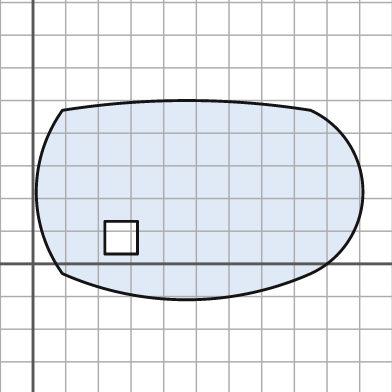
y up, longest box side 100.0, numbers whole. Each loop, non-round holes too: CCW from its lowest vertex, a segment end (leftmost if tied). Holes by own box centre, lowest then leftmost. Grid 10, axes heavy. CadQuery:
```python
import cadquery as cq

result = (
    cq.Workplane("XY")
    .moveTo(9.0, -3.0)
    .threePointArc((47.0, -11.0), (85.0, -3.0))
    .threePointArc((101.0, 22.0), (85.0, 47.0))
    .threePointArc((47.0, 50.0), (9.0, 47.0))
    .threePointArc((1.0, 22.0), (9.0, -3.0))
    .close()
    .moveTo(22.0, 3.0)
    .lineTo(32.0, 3.0)
    .lineTo(32.0, 13.0)
    .lineTo(22.0, 13.0)
    .close()
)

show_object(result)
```